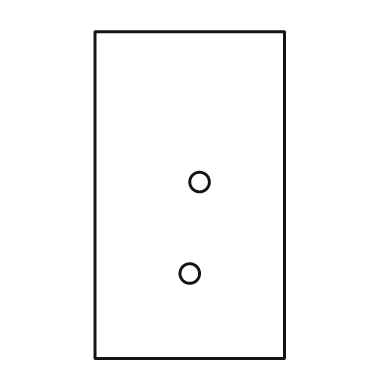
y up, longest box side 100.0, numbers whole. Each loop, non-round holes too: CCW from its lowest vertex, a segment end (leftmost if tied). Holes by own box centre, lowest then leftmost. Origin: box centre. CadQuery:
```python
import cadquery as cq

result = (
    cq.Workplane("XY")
    .moveTo(-29.0, -50.0)
    .lineTo(29.0, -50.0)
    .lineTo(29.0, 50.0)
    .lineTo(-29.0, 50.0)
    .close()
    .moveTo(0.0, -24.0)
    .circle(3.0)
    .moveTo(3.0, 4.0)
    .circle(3.0)
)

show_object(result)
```